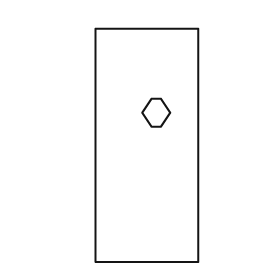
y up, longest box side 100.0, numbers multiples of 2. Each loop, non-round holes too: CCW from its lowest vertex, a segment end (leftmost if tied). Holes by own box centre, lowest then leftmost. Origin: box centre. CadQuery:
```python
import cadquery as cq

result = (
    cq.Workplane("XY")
    .moveTo(-22.0, -50.0)
    .lineTo(22.0, -50.0)
    .lineTo(22.0, 50.0)
    .lineTo(-22.0, 50.0)
    .close()
    .moveTo(2.0, 8.0)
    .lineTo(6.0, 8.0)
    .lineTo(10.0, 14.0)
    .lineTo(6.0, 20.0)
    .lineTo(2.0, 20.0)
    .lineTo(-2.0, 14.0)
    .close()
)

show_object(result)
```